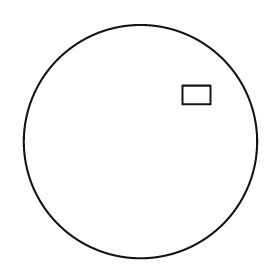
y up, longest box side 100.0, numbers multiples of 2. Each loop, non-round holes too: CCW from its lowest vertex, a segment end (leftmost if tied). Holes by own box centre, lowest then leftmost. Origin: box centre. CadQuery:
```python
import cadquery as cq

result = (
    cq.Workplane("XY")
    .moveTo(0.0, 0.0)
    .circle(50.0)
    .moveTo(18.0, 16.0)
    .lineTo(30.0, 16.0)
    .lineTo(30.0, 24.0)
    .lineTo(18.0, 24.0)
    .close()
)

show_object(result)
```